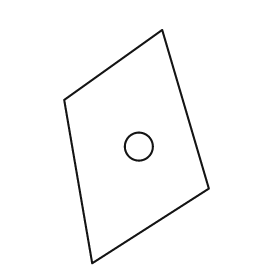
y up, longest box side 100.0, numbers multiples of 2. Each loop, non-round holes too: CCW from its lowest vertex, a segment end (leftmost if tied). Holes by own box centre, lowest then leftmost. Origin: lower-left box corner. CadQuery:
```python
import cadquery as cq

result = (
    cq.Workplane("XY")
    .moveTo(12.0, 0.0)
    .lineTo(62.0, 32.0)
    .lineTo(42.0, 100.0)
    .lineTo(0.0, 70.0)
    .close()
    .moveTo(32.0, 50.0)
    .circle(6.0)
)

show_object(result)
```